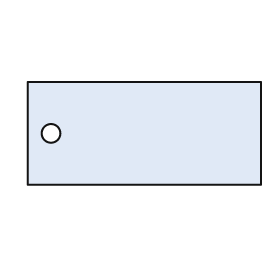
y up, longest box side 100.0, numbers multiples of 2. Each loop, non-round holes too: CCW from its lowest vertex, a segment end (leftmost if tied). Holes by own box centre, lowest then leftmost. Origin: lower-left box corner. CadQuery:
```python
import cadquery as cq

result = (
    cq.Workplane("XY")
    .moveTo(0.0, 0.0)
    .lineTo(100.0, 0.0)
    .lineTo(100.0, 44.0)
    .lineTo(0.0, 44.0)
    .close()
    .moveTo(10.0, 22.0)
    .circle(4.0)
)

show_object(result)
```